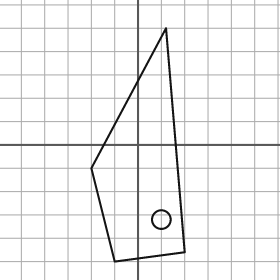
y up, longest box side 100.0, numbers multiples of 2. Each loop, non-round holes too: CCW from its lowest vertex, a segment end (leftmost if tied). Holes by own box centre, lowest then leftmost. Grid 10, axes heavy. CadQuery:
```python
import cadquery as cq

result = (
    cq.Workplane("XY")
    .moveTo(-10.0, -50.0)
    .lineTo(20.0, -46.0)
    .lineTo(12.0, 50.0)
    .lineTo(-20.0, -10.0)
    .close()
    .moveTo(10.0, -32.0)
    .circle(4.0)
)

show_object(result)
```